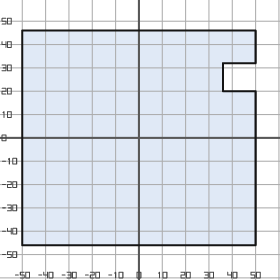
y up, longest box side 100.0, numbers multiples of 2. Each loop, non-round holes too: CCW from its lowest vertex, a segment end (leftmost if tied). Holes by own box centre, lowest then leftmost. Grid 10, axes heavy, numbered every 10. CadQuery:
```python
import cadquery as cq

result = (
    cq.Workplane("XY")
    .moveTo(-50.0, -46.0)
    .lineTo(50.0, -46.0)
    .lineTo(50.0, 20.0)
    .lineTo(36.0, 20.0)
    .lineTo(36.0, 32.0)
    .lineTo(50.0, 32.0)
    .lineTo(50.0, 46.0)
    .lineTo(-50.0, 46.0)
    .close()
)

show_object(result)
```